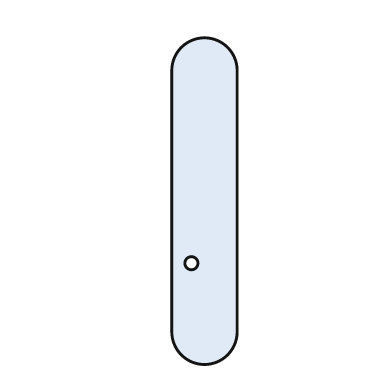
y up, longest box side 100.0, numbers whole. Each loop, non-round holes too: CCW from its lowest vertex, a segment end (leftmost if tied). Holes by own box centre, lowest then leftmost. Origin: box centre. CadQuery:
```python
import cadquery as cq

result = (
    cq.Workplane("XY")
    .moveTo(-10.0, -40.0)
    .threePointArc((0.0, -50.0), (10.0, -40.0))
    .lineTo(10.0, 40.0)
    .threePointArc((0.0, 50.0), (-10.0, 40.0))
    .close()
    .moveTo(-4.0, -19.0)
    .circle(2.0)
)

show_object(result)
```